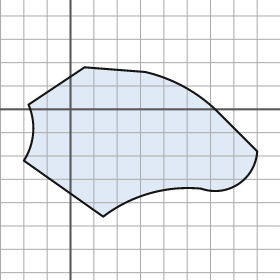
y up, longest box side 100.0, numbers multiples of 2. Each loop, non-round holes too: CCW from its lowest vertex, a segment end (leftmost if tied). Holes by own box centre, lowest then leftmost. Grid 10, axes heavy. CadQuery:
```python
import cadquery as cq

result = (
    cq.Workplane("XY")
    .moveTo(14.0, -46.0)
    .threePointArc((34.0, -36.0), (56.0, -34.0))
    .threePointArc((72.0, -32.0), (80.0, -18.0))
    .lineTo(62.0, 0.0)
    .threePointArc((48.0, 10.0), (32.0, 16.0))
    .lineTo(6.0, 18.0)
    .lineTo(-18.0, 2.0)
    .threePointArc((-16.0, -10.0), (-20.0, -22.0))
    .close()
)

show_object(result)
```